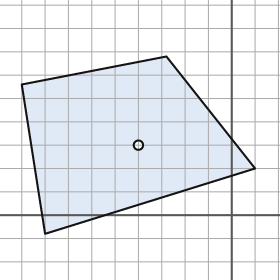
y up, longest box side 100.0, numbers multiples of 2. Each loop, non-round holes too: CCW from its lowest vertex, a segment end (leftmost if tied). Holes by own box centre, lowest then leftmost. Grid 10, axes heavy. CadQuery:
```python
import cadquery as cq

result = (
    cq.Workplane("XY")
    .moveTo(-80.0, -8.0)
    .lineTo(10.0, 20.0)
    .lineTo(-28.0, 68.0)
    .lineTo(-90.0, 56.0)
    .close()
    .moveTo(-40.0, 30.0)
    .circle(2.0)
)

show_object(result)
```